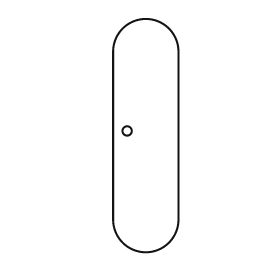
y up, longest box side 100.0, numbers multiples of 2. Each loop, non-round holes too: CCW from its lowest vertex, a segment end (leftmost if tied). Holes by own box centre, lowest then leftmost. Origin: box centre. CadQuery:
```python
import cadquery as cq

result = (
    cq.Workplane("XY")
    .moveTo(-14.0, -36.0)
    .threePointArc((0.0, -50.0), (14.0, -36.0))
    .lineTo(14.0, 36.0)
    .threePointArc((0.0, 50.0), (-14.0, 36.0))
    .close()
    .moveTo(-8.0, 2.0)
    .circle(2.0)
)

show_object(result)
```